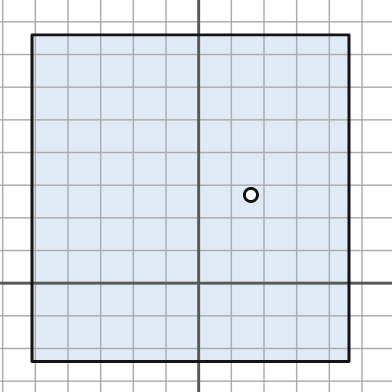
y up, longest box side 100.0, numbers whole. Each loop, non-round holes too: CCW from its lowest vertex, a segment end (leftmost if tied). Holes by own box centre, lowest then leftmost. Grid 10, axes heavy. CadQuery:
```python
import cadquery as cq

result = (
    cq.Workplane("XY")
    .moveTo(-51.0, -24.0)
    .lineTo(46.0, -24.0)
    .lineTo(46.0, 76.0)
    .lineTo(-51.0, 76.0)
    .close()
    .moveTo(16.0, 27.0)
    .circle(2.0)
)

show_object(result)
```